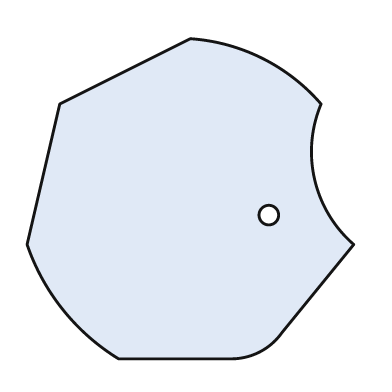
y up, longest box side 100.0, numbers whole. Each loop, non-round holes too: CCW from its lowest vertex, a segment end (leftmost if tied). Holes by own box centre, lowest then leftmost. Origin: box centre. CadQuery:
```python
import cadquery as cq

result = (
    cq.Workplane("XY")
    .moveTo(-22.0, -49.0)
    .lineTo(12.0, -49.0)
    .threePointArc((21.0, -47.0), (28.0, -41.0))
    .lineTo(50.0, -14.0)
    .threePointArc((38.0, 6.0), (40.0, 29.0))
    .threePointArc((22.0, 43.0), (0.0, 49.0))
    .lineTo(-40.0, 29.0)
    .lineTo(-50.0, -14.0)
    .threePointArc((-39.0, -34.0), (-22.0, -49.0))
    .close()
    .moveTo(24.0, -5.0)
    .circle(3.0)
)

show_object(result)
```